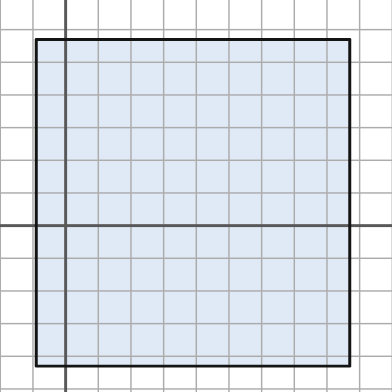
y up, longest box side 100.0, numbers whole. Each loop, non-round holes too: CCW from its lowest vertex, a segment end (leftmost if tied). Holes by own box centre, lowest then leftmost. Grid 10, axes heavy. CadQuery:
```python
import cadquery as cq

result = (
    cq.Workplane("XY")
    .moveTo(-9.0, -43.0)
    .lineTo(87.0, -43.0)
    .lineTo(87.0, 57.0)
    .lineTo(-9.0, 57.0)
    .close()
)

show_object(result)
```